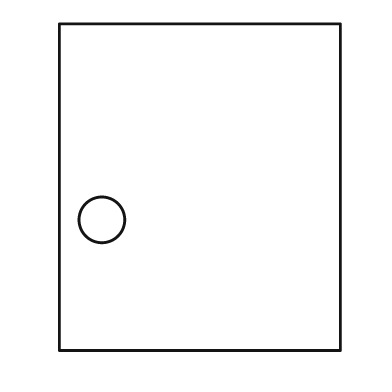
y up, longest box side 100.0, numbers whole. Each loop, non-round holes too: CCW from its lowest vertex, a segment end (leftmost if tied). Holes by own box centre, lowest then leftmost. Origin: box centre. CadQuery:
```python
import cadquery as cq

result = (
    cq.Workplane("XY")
    .moveTo(-43.0, -50.0)
    .lineTo(43.0, -50.0)
    .lineTo(43.0, 50.0)
    .lineTo(-43.0, 50.0)
    .close()
    .moveTo(-30.0, -10.0)
    .circle(7.0)
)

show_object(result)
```